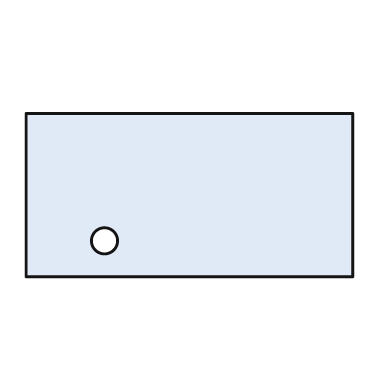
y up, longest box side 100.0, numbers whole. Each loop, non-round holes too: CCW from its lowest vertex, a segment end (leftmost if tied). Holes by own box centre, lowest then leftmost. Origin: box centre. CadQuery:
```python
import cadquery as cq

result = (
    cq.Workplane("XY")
    .moveTo(-50.0, -25.0)
    .lineTo(50.0, -25.0)
    .lineTo(50.0, 25.0)
    .lineTo(-50.0, 25.0)
    .close()
    .moveTo(-26.0, -14.0)
    .circle(4.0)
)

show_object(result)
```